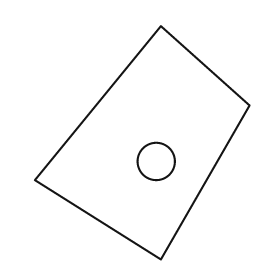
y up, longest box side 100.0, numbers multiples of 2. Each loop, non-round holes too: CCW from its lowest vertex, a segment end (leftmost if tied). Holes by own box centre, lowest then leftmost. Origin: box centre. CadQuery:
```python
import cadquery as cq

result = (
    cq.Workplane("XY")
    .moveTo(8.0, -50.0)
    .lineTo(46.0, 16.0)
    .lineTo(8.0, 50.0)
    .lineTo(-46.0, -16.0)
    .close()
    .moveTo(6.0, -8.0)
    .circle(8.0)
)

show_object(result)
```